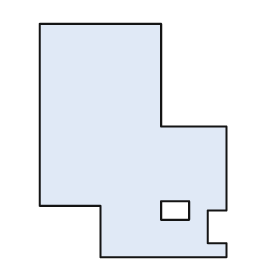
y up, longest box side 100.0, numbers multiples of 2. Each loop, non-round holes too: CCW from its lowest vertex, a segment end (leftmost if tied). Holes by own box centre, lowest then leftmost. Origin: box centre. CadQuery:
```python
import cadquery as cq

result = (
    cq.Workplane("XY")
    .moveTo(-14.0, -50.0)
    .lineTo(40.0, -50.0)
    .lineTo(40.0, -44.0)
    .lineTo(32.0, -44.0)
    .lineTo(32.0, -30.0)
    .lineTo(40.0, -30.0)
    .lineTo(40.0, 6.0)
    .lineTo(12.0, 6.0)
    .lineTo(12.0, 50.0)
    .lineTo(-40.0, 50.0)
    .lineTo(-40.0, -28.0)
    .lineTo(-14.0, -28.0)
    .close()
    .moveTo(12.0, -34.0)
    .lineTo(24.0, -34.0)
    .lineTo(24.0, -26.0)
    .lineTo(12.0, -26.0)
    .close()
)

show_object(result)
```